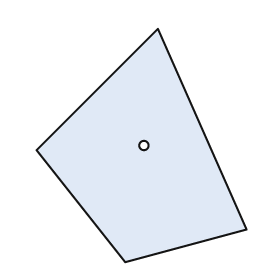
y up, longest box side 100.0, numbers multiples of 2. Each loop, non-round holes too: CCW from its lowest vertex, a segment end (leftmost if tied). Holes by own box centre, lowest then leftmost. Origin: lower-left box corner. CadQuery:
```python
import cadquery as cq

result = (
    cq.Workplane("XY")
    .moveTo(38.0, 0.0)
    .lineTo(90.0, 14.0)
    .lineTo(52.0, 100.0)
    .lineTo(0.0, 48.0)
    .close()
    .moveTo(46.0, 50.0)
    .circle(2.0)
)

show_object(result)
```